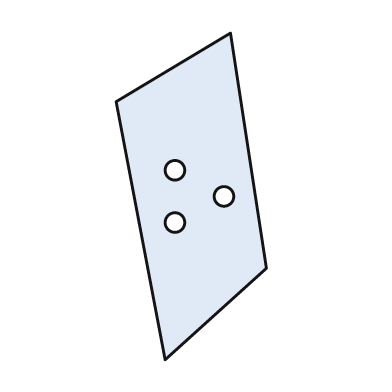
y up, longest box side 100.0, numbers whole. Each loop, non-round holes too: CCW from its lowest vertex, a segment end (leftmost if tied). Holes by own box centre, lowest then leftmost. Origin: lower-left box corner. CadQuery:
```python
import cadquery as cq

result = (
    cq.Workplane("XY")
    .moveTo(15.0, 0.0)
    .lineTo(46.0, 28.0)
    .lineTo(35.0, 100.0)
    .lineTo(0.0, 79.0)
    .close()
    .moveTo(18.0, 42.0)
    .circle(3.0)
    .moveTo(33.0, 50.0)
    .circle(3.0)
    .moveTo(18.0, 58.0)
    .circle(3.0)
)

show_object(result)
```